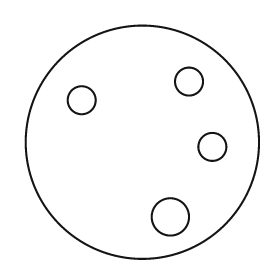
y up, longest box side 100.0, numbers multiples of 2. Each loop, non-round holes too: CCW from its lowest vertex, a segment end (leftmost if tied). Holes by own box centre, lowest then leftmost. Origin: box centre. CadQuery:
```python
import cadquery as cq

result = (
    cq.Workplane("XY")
    .moveTo(0.0, 0.0)
    .circle(50.0)
    .moveTo(12.0, -32.0)
    .circle(8.0)
    .moveTo(30.0, -2.0)
    .circle(6.0)
    .moveTo(-26.0, 18.0)
    .circle(6.0)
    .moveTo(20.0, 26.0)
    .circle(6.0)
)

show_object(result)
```